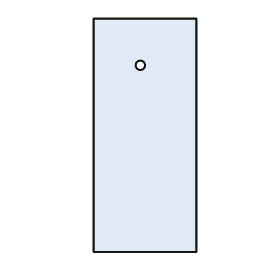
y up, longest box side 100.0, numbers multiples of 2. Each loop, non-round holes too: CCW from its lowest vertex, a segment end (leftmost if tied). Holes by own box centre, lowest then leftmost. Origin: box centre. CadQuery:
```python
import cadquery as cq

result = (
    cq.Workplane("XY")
    .moveTo(-22.0, -50.0)
    .lineTo(22.0, -50.0)
    .lineTo(22.0, 50.0)
    .lineTo(-22.0, 50.0)
    .close()
    .moveTo(-2.0, 30.0)
    .circle(2.0)
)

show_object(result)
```